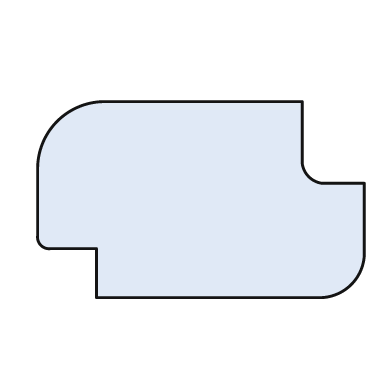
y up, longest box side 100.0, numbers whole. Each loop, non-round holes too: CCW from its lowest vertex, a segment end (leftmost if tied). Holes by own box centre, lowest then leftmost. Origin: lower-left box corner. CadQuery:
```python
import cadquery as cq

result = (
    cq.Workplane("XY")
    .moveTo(18.0, 0.0)
    .lineTo(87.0, 0.0)
    .threePointArc((96.0, 4.0), (100.0, 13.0))
    .lineTo(100.0, 35.0)
    .lineTo(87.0, 35.0)
    .threePointArc((83.0, 37.0), (81.0, 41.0))
    .lineTo(81.0, 60.0)
    .lineTo(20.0, 60.0)
    .threePointArc((6.0, 54.0), (0.0, 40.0))
    .lineTo(0.0, 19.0)
    .threePointArc((1.0, 16.0), (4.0, 15.0))
    .lineTo(18.0, 15.0)
    .close()
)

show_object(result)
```